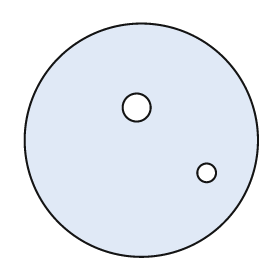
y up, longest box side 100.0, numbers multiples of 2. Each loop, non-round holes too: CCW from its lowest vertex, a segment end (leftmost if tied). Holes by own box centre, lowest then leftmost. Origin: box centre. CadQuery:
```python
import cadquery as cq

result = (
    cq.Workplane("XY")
    .moveTo(0.0, 0.0)
    .circle(50.0)
    .moveTo(28.0, -14.0)
    .circle(4.0)
    .moveTo(-2.0, 14.0)
    .circle(6.0)
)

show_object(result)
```